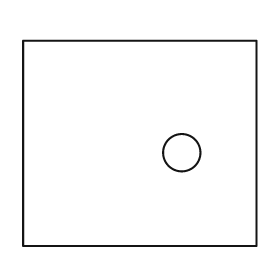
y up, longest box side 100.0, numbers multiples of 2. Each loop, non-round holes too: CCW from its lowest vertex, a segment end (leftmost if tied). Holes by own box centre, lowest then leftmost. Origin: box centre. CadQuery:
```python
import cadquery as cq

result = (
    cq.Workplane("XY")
    .moveTo(-50.0, -44.0)
    .lineTo(50.0, -44.0)
    .lineTo(50.0, 44.0)
    .lineTo(-50.0, 44.0)
    .close()
    .moveTo(18.0, -4.0)
    .circle(8.0)
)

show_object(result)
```